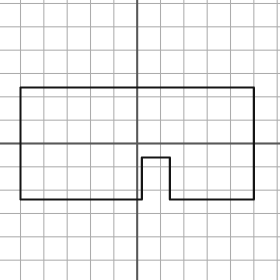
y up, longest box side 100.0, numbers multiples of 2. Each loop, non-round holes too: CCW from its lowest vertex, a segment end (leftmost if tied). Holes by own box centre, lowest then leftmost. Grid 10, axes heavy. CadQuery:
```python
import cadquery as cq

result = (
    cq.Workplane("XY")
    .moveTo(-50.0, -24.0)
    .lineTo(2.0, -24.0)
    .lineTo(2.0, -6.0)
    .lineTo(14.0, -6.0)
    .lineTo(14.0, -24.0)
    .lineTo(50.0, -24.0)
    .lineTo(50.0, 24.0)
    .lineTo(-50.0, 24.0)
    .close()
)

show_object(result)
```